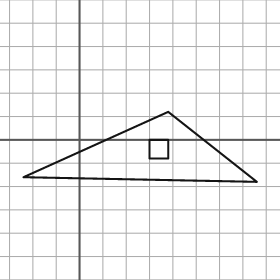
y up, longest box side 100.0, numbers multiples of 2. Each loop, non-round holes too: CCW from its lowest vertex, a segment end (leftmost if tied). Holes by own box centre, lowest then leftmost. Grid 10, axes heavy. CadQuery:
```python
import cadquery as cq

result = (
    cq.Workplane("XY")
    .moveTo(76.0, -18.0)
    .lineTo(38.0, 12.0)
    .lineTo(-24.0, -16.0)
    .close()
    .moveTo(30.0, -8.0)
    .lineTo(38.0, -8.0)
    .lineTo(38.0, 0.0)
    .lineTo(30.0, 0.0)
    .close()
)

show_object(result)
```